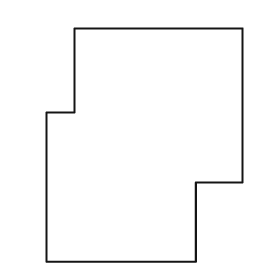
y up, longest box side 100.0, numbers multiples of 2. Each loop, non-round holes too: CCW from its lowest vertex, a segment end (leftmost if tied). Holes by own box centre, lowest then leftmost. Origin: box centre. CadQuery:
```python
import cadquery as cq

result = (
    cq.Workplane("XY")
    .moveTo(-42.0, -50.0)
    .lineTo(22.0, -50.0)
    .lineTo(22.0, -16.0)
    .lineTo(42.0, -16.0)
    .lineTo(42.0, 50.0)
    .lineTo(-30.0, 50.0)
    .lineTo(-30.0, 14.0)
    .lineTo(-42.0, 14.0)
    .close()
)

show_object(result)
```